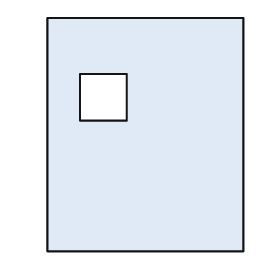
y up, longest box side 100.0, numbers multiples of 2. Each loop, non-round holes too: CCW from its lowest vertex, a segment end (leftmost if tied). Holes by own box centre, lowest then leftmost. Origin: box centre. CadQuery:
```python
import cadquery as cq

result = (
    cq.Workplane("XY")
    .moveTo(-42.0, -50.0)
    .lineTo(42.0, -50.0)
    .lineTo(42.0, 50.0)
    .lineTo(-42.0, 50.0)
    .close()
    .moveTo(-28.0, 6.0)
    .lineTo(-8.0, 6.0)
    .lineTo(-8.0, 26.0)
    .lineTo(-28.0, 26.0)
    .close()
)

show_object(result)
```